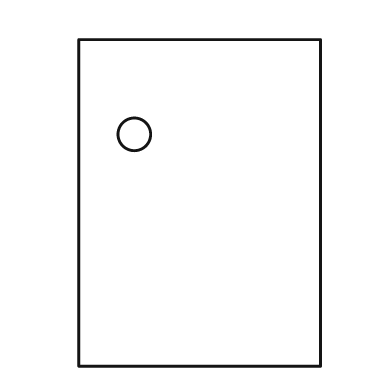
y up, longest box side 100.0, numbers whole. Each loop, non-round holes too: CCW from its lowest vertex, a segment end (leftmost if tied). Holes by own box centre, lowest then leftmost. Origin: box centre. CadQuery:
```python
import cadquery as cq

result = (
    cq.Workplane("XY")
    .moveTo(-37.0, -50.0)
    .lineTo(37.0, -50.0)
    .lineTo(37.0, 50.0)
    .lineTo(-37.0, 50.0)
    .close()
    .moveTo(-20.0, 21.0)
    .circle(5.0)
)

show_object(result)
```